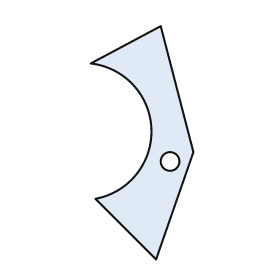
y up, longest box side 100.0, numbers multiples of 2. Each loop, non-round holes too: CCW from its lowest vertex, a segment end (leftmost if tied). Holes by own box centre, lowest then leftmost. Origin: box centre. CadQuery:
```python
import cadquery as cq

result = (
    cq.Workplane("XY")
    .moveTo(6.0, -50.0)
    .lineTo(22.0, -4.0)
    .lineTo(8.0, 50.0)
    .lineTo(-22.0, 34.0)
    .threePointArc((4.0, 6.0), (-20.0, -24.0))
    .close()
    .moveTo(12.0, -8.0)
    .circle(4.0)
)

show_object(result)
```